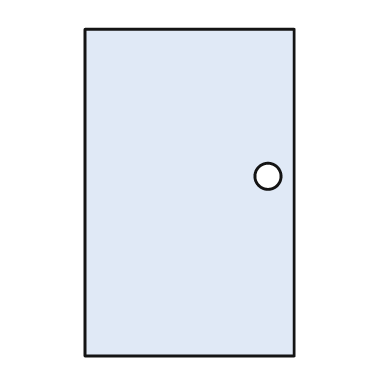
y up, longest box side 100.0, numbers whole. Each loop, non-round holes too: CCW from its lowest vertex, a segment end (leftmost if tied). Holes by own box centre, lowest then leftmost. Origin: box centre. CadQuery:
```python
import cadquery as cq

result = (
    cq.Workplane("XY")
    .moveTo(-32.0, -50.0)
    .lineTo(32.0, -50.0)
    .lineTo(32.0, 50.0)
    .lineTo(-32.0, 50.0)
    .close()
    .moveTo(24.0, 5.0)
    .circle(4.0)
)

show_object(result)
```